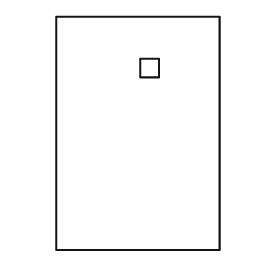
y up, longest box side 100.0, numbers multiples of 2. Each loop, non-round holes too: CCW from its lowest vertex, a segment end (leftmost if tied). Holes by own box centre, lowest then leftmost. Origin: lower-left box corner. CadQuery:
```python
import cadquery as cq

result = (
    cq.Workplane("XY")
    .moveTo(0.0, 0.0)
    .lineTo(70.0, 0.0)
    .lineTo(70.0, 100.0)
    .lineTo(0.0, 100.0)
    .close()
    .moveTo(36.0, 74.0)
    .lineTo(44.0, 74.0)
    .lineTo(44.0, 82.0)
    .lineTo(36.0, 82.0)
    .close()
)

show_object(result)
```